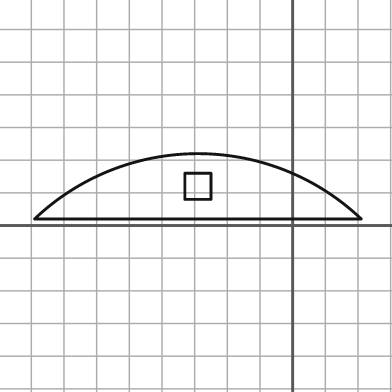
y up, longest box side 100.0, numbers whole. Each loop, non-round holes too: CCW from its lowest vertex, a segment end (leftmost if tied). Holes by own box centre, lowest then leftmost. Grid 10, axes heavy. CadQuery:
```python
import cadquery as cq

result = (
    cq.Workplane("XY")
    .moveTo(-79.0, 2.0)
    .lineTo(21.0, 2.0)
    .threePointArc((-29.0, 22.0), (-79.0, 2.0))
    .close()
    .moveTo(-33.0, 8.0)
    .lineTo(-25.0, 8.0)
    .lineTo(-25.0, 16.0)
    .lineTo(-33.0, 16.0)
    .close()
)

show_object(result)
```